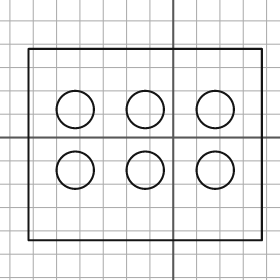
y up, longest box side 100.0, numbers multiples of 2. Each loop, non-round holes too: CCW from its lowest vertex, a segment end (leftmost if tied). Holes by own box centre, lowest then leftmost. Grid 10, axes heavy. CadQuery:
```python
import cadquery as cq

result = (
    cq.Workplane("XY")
    .moveTo(-62.0, -44.0)
    .lineTo(38.0, -44.0)
    .lineTo(38.0, 38.0)
    .lineTo(-62.0, 38.0)
    .close()
    .moveTo(-42.0, -14.0)
    .circle(8.0)
    .moveTo(-12.0, -14.0)
    .circle(8.0)
    .moveTo(18.0, -14.0)
    .circle(8.0)
    .moveTo(-42.0, 12.0)
    .circle(8.0)
    .moveTo(-12.0, 12.0)
    .circle(8.0)
    .moveTo(18.0, 12.0)
    .circle(8.0)
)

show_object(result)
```